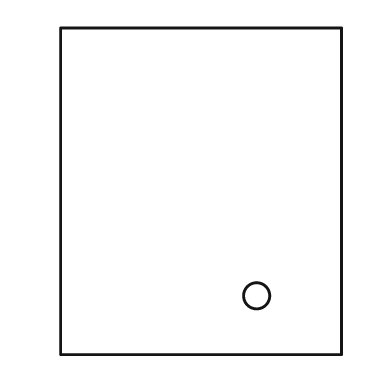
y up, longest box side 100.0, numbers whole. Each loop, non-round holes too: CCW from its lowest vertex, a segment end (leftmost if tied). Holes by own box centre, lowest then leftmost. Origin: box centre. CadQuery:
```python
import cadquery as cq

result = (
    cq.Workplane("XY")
    .moveTo(-43.0, -50.0)
    .lineTo(43.0, -50.0)
    .lineTo(43.0, 50.0)
    .lineTo(-43.0, 50.0)
    .close()
    .moveTo(17.0, -32.0)
    .circle(4.0)
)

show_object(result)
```